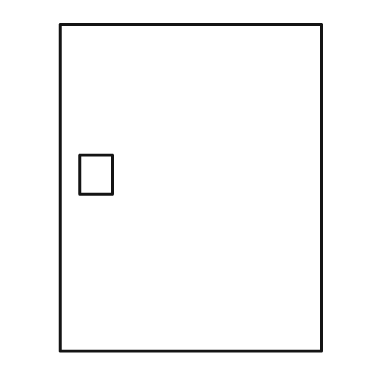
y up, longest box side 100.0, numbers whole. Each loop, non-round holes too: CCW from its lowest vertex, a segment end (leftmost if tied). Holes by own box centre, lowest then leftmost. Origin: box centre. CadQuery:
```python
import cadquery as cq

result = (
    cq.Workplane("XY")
    .moveTo(-40.0, -50.0)
    .lineTo(40.0, -50.0)
    .lineTo(40.0, 50.0)
    .lineTo(-40.0, 50.0)
    .close()
    .moveTo(-34.0, -2.0)
    .lineTo(-24.0, -2.0)
    .lineTo(-24.0, 10.0)
    .lineTo(-34.0, 10.0)
    .close()
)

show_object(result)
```